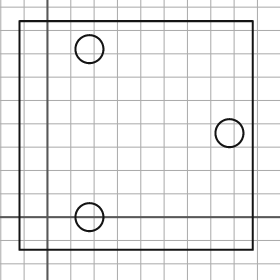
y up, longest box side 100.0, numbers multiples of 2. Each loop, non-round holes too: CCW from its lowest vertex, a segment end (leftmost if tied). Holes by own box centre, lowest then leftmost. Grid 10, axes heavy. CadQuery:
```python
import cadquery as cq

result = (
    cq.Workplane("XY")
    .moveTo(-12.0, -14.0)
    .lineTo(88.0, -14.0)
    .lineTo(88.0, 84.0)
    .lineTo(-12.0, 84.0)
    .close()
    .moveTo(18.0, 0.0)
    .circle(6.0)
    .moveTo(78.0, 36.0)
    .circle(6.0)
    .moveTo(18.0, 72.0)
    .circle(6.0)
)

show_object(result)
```